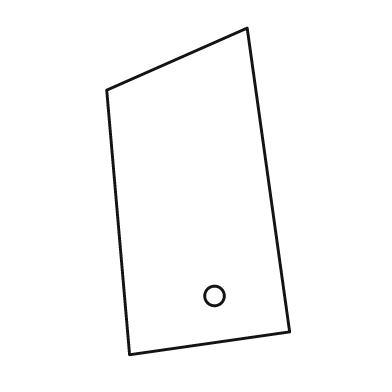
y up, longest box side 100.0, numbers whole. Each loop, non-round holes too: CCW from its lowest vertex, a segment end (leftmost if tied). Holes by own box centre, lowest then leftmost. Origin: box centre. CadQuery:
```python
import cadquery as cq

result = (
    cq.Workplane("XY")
    .moveTo(-21.0, -50.0)
    .lineTo(28.0, -43.0)
    .lineTo(15.0, 50.0)
    .lineTo(-28.0, 31.0)
    .close()
    .moveTo(5.0, -32.0)
    .circle(3.0)
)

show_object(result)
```